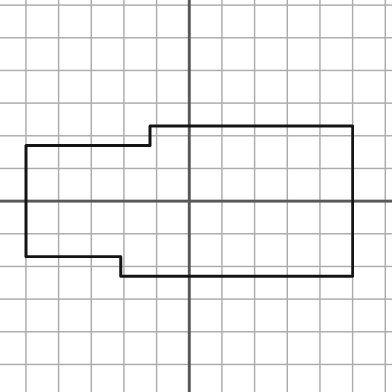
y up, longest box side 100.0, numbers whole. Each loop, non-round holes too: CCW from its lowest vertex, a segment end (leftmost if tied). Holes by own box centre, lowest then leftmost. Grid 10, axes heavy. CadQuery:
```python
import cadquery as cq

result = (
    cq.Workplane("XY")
    .moveTo(-21.0, -23.0)
    .lineTo(50.0, -23.0)
    .lineTo(50.0, 23.0)
    .lineTo(-12.0, 23.0)
    .lineTo(-12.0, 17.0)
    .lineTo(-50.0, 17.0)
    .lineTo(-50.0, -17.0)
    .lineTo(-21.0, -17.0)
    .close()
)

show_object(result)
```